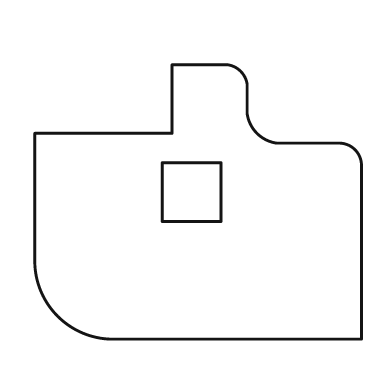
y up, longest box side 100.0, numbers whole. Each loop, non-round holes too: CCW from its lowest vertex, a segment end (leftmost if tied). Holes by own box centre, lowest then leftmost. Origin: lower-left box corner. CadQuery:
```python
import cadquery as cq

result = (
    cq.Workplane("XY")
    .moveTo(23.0, 0.0)
    .lineTo(100.0, 0.0)
    .lineTo(100.0, 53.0)
    .threePointArc((98.0, 58.0), (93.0, 60.0))
    .lineTo(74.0, 60.0)
    .threePointArc((68.0, 63.0), (65.0, 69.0))
    .lineTo(65.0, 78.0)
    .threePointArc((63.0, 82.0), (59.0, 84.0))
    .lineTo(42.0, 84.0)
    .lineTo(42.0, 63.0)
    .lineTo(0.0, 63.0)
    .lineTo(0.0, 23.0)
    .threePointArc((7.0, 7.0), (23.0, 0.0))
    .close()
    .moveTo(39.0, 36.0)
    .lineTo(57.0, 36.0)
    .lineTo(57.0, 54.0)
    .lineTo(39.0, 54.0)
    .close()
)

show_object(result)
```